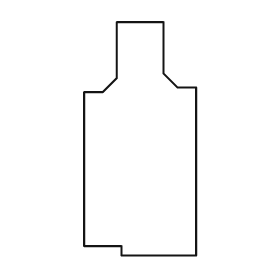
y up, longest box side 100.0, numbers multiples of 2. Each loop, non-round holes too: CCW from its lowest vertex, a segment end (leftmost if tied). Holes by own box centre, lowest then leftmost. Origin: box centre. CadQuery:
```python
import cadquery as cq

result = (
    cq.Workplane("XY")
    .moveTo(-8.0, -50.0)
    .lineTo(24.0, -50.0)
    .lineTo(24.0, 22.0)
    .lineTo(16.0, 22.0)
    .lineTo(10.0, 28.0)
    .lineTo(10.0, 50.0)
    .lineTo(-10.0, 50.0)
    .lineTo(-10.0, 26.0)
    .lineTo(-16.0, 20.0)
    .lineTo(-24.0, 20.0)
    .lineTo(-24.0, -46.0)
    .lineTo(-8.0, -46.0)
    .close()
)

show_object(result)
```